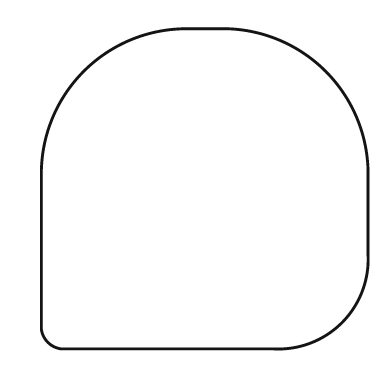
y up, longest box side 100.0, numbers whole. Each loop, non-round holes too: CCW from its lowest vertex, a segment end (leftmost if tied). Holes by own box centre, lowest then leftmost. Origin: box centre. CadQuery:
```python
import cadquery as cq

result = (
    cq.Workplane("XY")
    .moveTo(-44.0, -49.0)
    .lineTo(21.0, -49.0)
    .threePointArc((42.0, -41.0), (50.0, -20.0))
    .lineTo(50.0, 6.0)
    .threePointArc((37.0, 36.0), (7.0, 49.0))
    .lineTo(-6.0, 49.0)
    .threePointArc((-37.0, 36.0), (-50.0, 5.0))
    .lineTo(-50.0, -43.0)
    .threePointArc((-48.0, -47.0), (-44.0, -49.0))
    .close()
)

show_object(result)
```